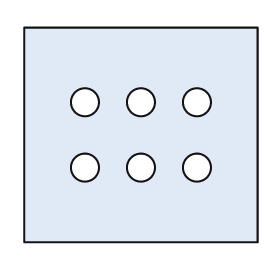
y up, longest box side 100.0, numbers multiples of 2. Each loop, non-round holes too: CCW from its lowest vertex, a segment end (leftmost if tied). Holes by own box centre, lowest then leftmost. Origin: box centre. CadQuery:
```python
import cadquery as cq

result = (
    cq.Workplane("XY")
    .moveTo(-50.0, -46.0)
    .lineTo(50.0, -46.0)
    .lineTo(50.0, 46.0)
    .lineTo(-50.0, 46.0)
    .close()
    .moveTo(-24.0, -14.0)
    .circle(6.0)
    .moveTo(0.0, -14.0)
    .circle(6.0)
    .moveTo(24.0, -14.0)
    .circle(6.0)
    .moveTo(-24.0, 14.0)
    .circle(6.0)
    .moveTo(0.0, 14.0)
    .circle(6.0)
    .moveTo(24.0, 14.0)
    .circle(6.0)
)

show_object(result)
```